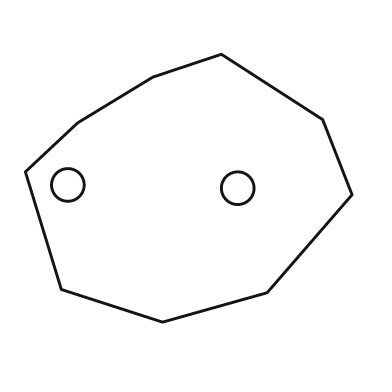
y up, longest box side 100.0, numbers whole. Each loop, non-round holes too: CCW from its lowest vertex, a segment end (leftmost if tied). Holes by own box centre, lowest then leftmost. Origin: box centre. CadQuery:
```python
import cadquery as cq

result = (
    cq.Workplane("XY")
    .moveTo(-8.0, -41.0)
    .lineTo(24.0, -32.0)
    .lineTo(50.0, -2.0)
    .lineTo(41.0, 21.0)
    .lineTo(10.0, 41.0)
    .lineTo(-11.0, 34.0)
    .lineTo(-34.0, 20.0)
    .lineTo(-50.0, 5.0)
    .lineTo(-39.0, -31.0)
    .close()
    .moveTo(15.0, 0.0)
    .circle(5.0)
    .moveTo(-37.0, 1.0)
    .circle(5.0)
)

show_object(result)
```